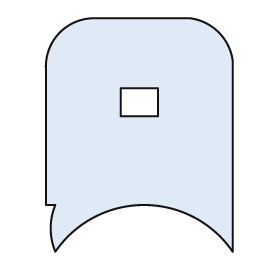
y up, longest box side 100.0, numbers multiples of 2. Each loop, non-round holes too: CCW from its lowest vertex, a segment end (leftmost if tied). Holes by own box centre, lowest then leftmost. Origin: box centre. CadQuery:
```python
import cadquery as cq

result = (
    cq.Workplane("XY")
    .moveTo(-36.0, -50.0)
    .threePointArc((2.0, -30.0), (40.0, -50.0))
    .lineTo(40.0, 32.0)
    .threePointArc((34.0, 44.0), (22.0, 50.0))
    .lineTo(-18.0, 50.0)
    .threePointArc((-34.0, 44.0), (-40.0, 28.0))
    .lineTo(-40.0, -30.0)
    .lineTo(-36.0, -30.0)
    .threePointArc((-38.0, -40.0), (-36.0, -50.0))
    .close()
    .moveTo(-8.0, 8.0)
    .lineTo(8.0, 8.0)
    .lineTo(8.0, 20.0)
    .lineTo(-8.0, 20.0)
    .close()
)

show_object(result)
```